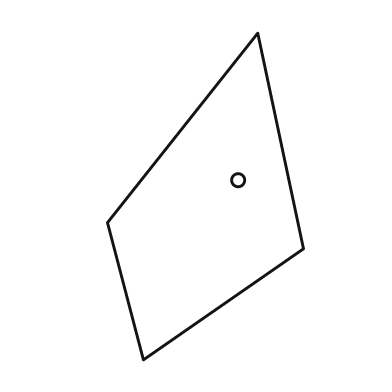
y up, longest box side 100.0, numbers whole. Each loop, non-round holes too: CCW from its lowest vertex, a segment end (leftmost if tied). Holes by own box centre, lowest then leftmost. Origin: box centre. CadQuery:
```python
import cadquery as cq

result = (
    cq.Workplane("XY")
    .moveTo(-19.0, -50.0)
    .lineTo(30.0, -16.0)
    .lineTo(16.0, 50.0)
    .lineTo(-30.0, -8.0)
    .close()
    .moveTo(10.0, 5.0)
    .circle(2.0)
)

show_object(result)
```